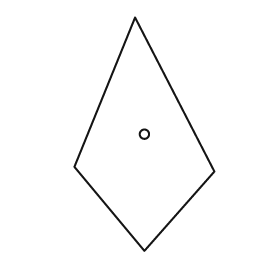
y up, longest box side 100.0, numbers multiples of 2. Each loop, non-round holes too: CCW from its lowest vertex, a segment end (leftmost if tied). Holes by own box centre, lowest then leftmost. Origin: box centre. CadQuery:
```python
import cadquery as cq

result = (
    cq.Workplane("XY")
    .moveTo(0.0, -50.0)
    .lineTo(30.0, -16.0)
    .lineTo(-4.0, 50.0)
    .lineTo(-30.0, -14.0)
    .close()
    .moveTo(0.0, 0.0)
    .circle(2.0)
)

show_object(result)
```